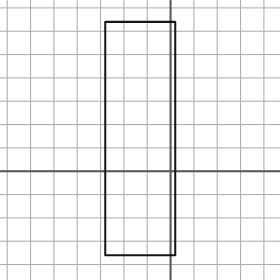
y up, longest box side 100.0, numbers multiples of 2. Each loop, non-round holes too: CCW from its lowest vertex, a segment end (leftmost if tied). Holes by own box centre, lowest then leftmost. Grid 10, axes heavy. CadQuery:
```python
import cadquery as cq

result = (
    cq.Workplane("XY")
    .moveTo(-28.0, -36.0)
    .lineTo(2.0, -36.0)
    .lineTo(2.0, 64.0)
    .lineTo(-28.0, 64.0)
    .close()
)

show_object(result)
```